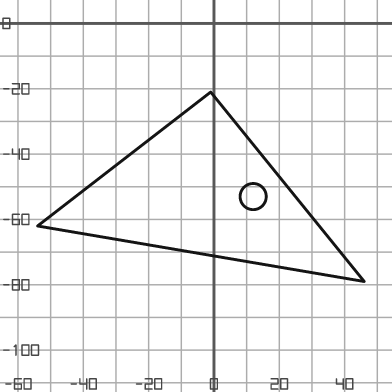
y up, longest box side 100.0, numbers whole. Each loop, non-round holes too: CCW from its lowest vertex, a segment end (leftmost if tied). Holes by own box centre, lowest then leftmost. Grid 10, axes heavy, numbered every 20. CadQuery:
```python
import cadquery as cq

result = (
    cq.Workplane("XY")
    .moveTo(46.0, -79.0)
    .lineTo(-1.0, -21.0)
    .lineTo(-54.0, -62.0)
    .close()
    .moveTo(12.0, -53.0)
    .circle(4.0)
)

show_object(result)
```